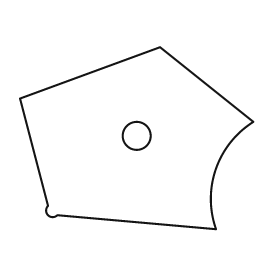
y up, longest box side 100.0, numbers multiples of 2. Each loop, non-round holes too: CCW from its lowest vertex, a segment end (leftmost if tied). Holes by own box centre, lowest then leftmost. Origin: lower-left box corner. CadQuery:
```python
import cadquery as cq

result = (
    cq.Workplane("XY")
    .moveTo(84.0, 0.0)
    .threePointArc((84.0, 26.0), (100.0, 46.0))
    .lineTo(60.0, 78.0)
    .lineTo(0.0, 56.0)
    .lineTo(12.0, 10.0)
    .threePointArc((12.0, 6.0), (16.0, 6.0))
    .close()
    .moveTo(50.0, 40.0)
    .circle(6.0)
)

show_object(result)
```